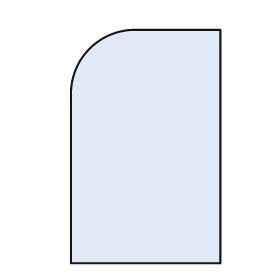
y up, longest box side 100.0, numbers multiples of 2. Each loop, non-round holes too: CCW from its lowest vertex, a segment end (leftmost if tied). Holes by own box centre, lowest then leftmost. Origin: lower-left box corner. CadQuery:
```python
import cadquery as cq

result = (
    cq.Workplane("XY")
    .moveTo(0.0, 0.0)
    .lineTo(64.0, 0.0)
    .lineTo(64.0, 100.0)
    .lineTo(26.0, 100.0)
    .threePointArc((8.0, 92.0), (0.0, 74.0))
    .close()
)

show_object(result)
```